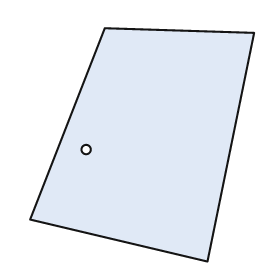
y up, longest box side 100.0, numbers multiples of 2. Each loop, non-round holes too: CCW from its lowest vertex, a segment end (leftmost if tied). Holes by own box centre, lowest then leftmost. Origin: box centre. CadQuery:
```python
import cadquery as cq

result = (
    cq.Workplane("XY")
    .moveTo(28.0, -50.0)
    .lineTo(48.0, 48.0)
    .lineTo(-16.0, 50.0)
    .lineTo(-48.0, -32.0)
    .close()
    .moveTo(-24.0, -2.0)
    .circle(2.0)
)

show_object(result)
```